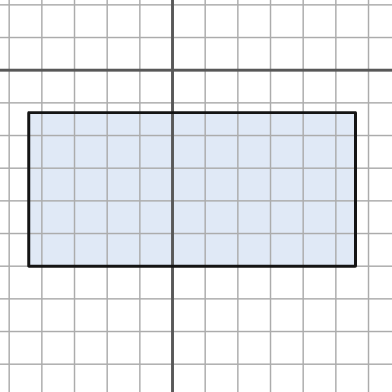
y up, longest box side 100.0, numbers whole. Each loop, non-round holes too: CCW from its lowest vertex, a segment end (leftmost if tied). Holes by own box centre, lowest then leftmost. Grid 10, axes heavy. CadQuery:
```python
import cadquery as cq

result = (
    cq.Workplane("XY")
    .moveTo(-44.0, -60.0)
    .lineTo(56.0, -60.0)
    .lineTo(56.0, -13.0)
    .lineTo(-44.0, -13.0)
    .close()
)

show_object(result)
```